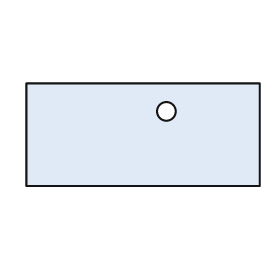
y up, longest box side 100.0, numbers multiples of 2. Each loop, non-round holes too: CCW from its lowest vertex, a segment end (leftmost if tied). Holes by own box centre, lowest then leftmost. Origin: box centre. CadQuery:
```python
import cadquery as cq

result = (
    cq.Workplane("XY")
    .moveTo(-50.0, -22.0)
    .lineTo(50.0, -22.0)
    .lineTo(50.0, 22.0)
    .lineTo(-50.0, 22.0)
    .close()
    .moveTo(10.0, 10.0)
    .circle(4.0)
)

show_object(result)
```